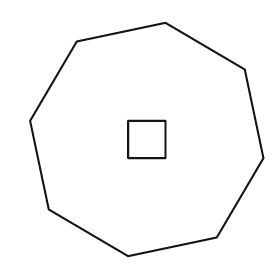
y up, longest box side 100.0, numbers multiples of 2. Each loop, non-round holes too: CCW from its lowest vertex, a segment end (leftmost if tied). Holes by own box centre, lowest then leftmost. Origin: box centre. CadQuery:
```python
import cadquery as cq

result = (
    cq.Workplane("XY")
    .moveTo(-8.0, -50.0)
    .lineTo(30.0, -42.0)
    .lineTo(50.0, -8.0)
    .lineTo(42.0, 30.0)
    .lineTo(8.0, 50.0)
    .lineTo(-30.0, 42.0)
    .lineTo(-50.0, 8.0)
    .lineTo(-42.0, -30.0)
    .close()
    .moveTo(-8.0, -8.0)
    .lineTo(8.0, -8.0)
    .lineTo(8.0, 8.0)
    .lineTo(-8.0, 8.0)
    .close()
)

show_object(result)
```